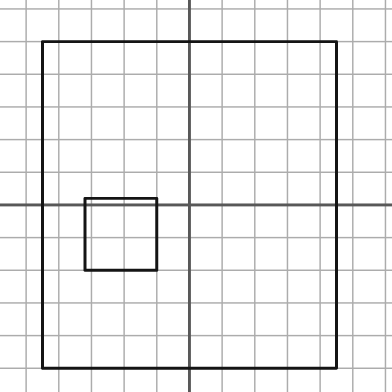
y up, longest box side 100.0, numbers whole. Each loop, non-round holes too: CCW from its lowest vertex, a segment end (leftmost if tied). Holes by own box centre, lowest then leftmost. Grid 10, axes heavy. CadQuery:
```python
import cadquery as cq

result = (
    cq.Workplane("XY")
    .moveTo(-45.0, -50.0)
    .lineTo(45.0, -50.0)
    .lineTo(45.0, 50.0)
    .lineTo(-45.0, 50.0)
    .close()
    .moveTo(-32.0, -20.0)
    .lineTo(-10.0, -20.0)
    .lineTo(-10.0, 2.0)
    .lineTo(-32.0, 2.0)
    .close()
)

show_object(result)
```